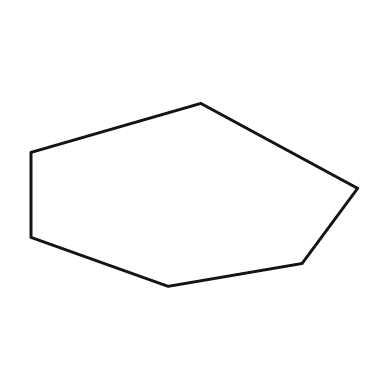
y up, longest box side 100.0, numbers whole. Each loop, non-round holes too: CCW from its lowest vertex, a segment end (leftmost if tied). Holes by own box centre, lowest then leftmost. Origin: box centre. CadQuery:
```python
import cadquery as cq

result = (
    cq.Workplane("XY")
    .moveTo(-8.0, -28.0)
    .lineTo(33.0, -21.0)
    .lineTo(50.0, 2.0)
    .lineTo(2.0, 28.0)
    .lineTo(-50.0, 13.0)
    .lineTo(-50.0, -13.0)
    .close()
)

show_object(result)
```